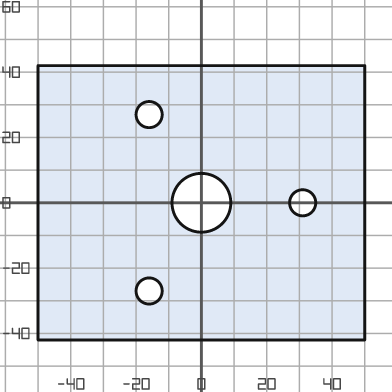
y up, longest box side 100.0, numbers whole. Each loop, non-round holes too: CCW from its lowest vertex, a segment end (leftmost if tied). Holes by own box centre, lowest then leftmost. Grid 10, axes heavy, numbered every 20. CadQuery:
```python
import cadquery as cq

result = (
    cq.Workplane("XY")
    .moveTo(-50.0, -42.0)
    .lineTo(50.0, -42.0)
    .lineTo(50.0, 42.0)
    .lineTo(-50.0, 42.0)
    .close()
    .moveTo(-16.0, -27.0)
    .circle(4.0)
    .moveTo(0.0, 0.0)
    .circle(9.0)
    .moveTo(31.0, 0.0)
    .circle(4.0)
    .moveTo(-16.0, 27.0)
    .circle(4.0)
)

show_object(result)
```